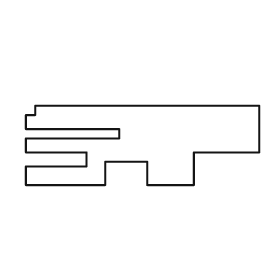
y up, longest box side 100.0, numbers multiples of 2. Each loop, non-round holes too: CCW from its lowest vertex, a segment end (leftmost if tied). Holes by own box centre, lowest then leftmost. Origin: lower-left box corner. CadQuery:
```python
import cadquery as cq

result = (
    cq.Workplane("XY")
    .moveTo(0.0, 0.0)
    .lineTo(34.0, 0.0)
    .lineTo(34.0, 10.0)
    .lineTo(52.0, 10.0)
    .lineTo(52.0, 0.0)
    .lineTo(72.0, 0.0)
    .lineTo(72.0, 14.0)
    .lineTo(100.0, 14.0)
    .lineTo(100.0, 34.0)
    .lineTo(4.0, 34.0)
    .lineTo(4.0, 30.0)
    .lineTo(0.0, 30.0)
    .lineTo(0.0, 24.0)
    .lineTo(40.0, 24.0)
    .lineTo(40.0, 20.0)
    .lineTo(0.0, 20.0)
    .lineTo(0.0, 14.0)
    .lineTo(26.0, 14.0)
    .lineTo(26.0, 8.0)
    .lineTo(0.0, 8.0)
    .close()
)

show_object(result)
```